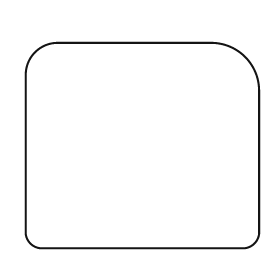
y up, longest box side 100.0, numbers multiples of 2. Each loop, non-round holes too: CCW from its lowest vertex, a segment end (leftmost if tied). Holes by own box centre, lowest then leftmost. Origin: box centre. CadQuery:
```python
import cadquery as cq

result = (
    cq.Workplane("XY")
    .moveTo(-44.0, -44.0)
    .lineTo(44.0, -44.0)
    .threePointArc((48.0, -42.0), (50.0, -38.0))
    .lineTo(50.0, 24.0)
    .threePointArc((44.0, 38.0), (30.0, 44.0))
    .lineTo(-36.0, 44.0)
    .threePointArc((-46.0, 40.0), (-50.0, 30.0))
    .lineTo(-50.0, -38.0)
    .threePointArc((-48.0, -42.0), (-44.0, -44.0))
    .close()
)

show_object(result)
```